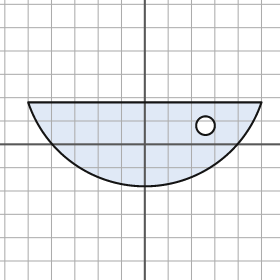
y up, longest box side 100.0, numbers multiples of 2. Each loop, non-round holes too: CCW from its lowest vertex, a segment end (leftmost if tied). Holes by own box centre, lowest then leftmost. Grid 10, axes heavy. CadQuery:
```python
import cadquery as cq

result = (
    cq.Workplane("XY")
    .moveTo(-50.0, 18.0)
    .threePointArc((0.0, -18.0), (50.0, 18.0))
    .close()
    .moveTo(26.0, 8.0)
    .circle(4.0)
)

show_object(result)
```